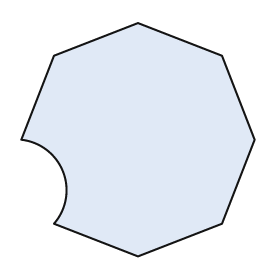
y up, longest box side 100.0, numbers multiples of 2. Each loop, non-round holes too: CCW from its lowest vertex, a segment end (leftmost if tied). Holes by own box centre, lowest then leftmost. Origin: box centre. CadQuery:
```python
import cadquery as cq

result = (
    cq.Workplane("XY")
    .moveTo(0.0, -50.0)
    .lineTo(36.0, -36.0)
    .lineTo(50.0, 0.0)
    .lineTo(36.0, 36.0)
    .lineTo(0.0, 50.0)
    .lineTo(-36.0, 36.0)
    .lineTo(-50.0, 0.0)
    .threePointArc((-32.0, -14.0), (-36.0, -36.0))
    .close()
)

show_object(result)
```